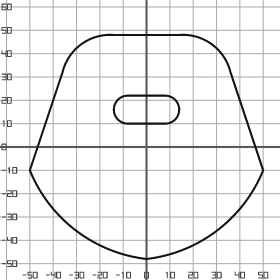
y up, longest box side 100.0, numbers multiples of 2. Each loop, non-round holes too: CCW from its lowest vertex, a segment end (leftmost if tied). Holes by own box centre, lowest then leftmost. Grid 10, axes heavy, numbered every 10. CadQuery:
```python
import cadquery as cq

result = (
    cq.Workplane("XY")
    .moveTo(0.0, -48.0)
    .threePointArc((30.0, -36.0), (50.0, -10.0))
    .lineTo(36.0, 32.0)
    .threePointArc((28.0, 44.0), (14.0, 48.0))
    .lineTo(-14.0, 48.0)
    .threePointArc((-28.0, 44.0), (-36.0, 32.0))
    .lineTo(-50.0, -10.0)
    .threePointArc((-30.0, -36.0), (0.0, -48.0))
    .close()
    .moveTo(-8.0, 10.0)
    .lineTo(8.0, 10.0)
    .threePointArc((14.0, 16.0), (8.0, 22.0))
    .lineTo(-8.0, 22.0)
    .threePointArc((-14.0, 16.0), (-8.0, 10.0))
    .close()
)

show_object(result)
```